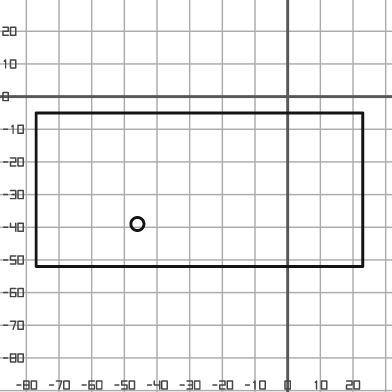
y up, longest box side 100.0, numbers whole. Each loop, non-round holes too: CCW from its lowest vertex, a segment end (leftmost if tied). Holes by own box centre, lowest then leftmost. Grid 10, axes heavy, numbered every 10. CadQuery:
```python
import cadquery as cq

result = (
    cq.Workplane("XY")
    .moveTo(-77.0, -52.0)
    .lineTo(23.0, -52.0)
    .lineTo(23.0, -5.0)
    .lineTo(-77.0, -5.0)
    .close()
    .moveTo(-46.0, -39.0)
    .circle(2.0)
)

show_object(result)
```